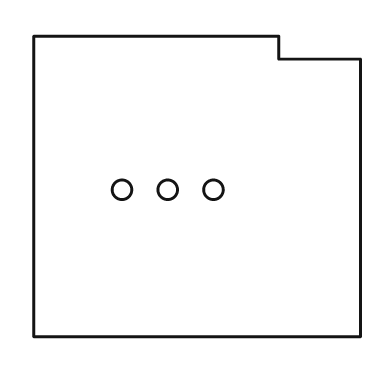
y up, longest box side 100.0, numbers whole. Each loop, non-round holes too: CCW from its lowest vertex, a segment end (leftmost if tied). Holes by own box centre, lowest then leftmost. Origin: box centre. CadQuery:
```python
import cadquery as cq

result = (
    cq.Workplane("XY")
    .moveTo(-50.0, -46.0)
    .lineTo(50.0, -46.0)
    .lineTo(50.0, 39.0)
    .lineTo(25.0, 39.0)
    .lineTo(25.0, 46.0)
    .lineTo(-50.0, 46.0)
    .close()
    .moveTo(-23.0, -1.0)
    .circle(3.0)
    .moveTo(-9.0, -1.0)
    .circle(3.0)
    .moveTo(5.0, -1.0)
    .circle(3.0)
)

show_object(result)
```